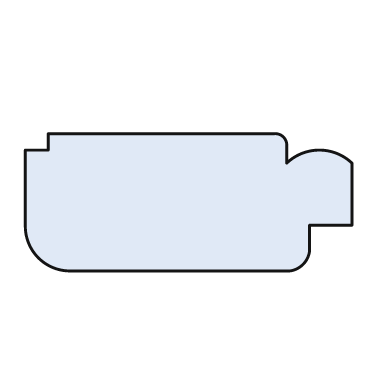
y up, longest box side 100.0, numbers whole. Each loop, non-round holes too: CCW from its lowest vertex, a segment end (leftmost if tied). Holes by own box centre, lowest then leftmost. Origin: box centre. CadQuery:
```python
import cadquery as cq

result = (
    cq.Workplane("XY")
    .moveTo(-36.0, -21.0)
    .lineTo(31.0, -21.0)
    .threePointArc((35.0, -19.0), (37.0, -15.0))
    .lineTo(37.0, -7.0)
    .lineTo(50.0, -7.0)
    .lineTo(50.0, 12.0)
    .threePointArc((40.0, 16.0), (30.0, 12.0))
    .lineTo(30.0, 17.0)
    .threePointArc((29.0, 20.0), (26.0, 21.0))
    .lineTo(-43.0, 21.0)
    .lineTo(-43.0, 16.0)
    .lineTo(-50.0, 16.0)
    .lineTo(-50.0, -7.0)
    .threePointArc((-46.0, -17.0), (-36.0, -21.0))
    .close()
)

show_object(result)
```